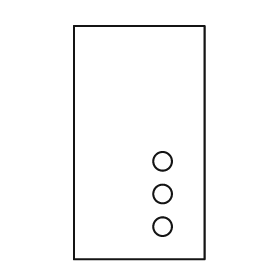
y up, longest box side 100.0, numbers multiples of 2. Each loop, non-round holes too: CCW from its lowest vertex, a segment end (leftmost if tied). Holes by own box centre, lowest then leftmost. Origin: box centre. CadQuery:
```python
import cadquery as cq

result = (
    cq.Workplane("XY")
    .moveTo(-28.0, -50.0)
    .lineTo(28.0, -50.0)
    .lineTo(28.0, 50.0)
    .lineTo(-28.0, 50.0)
    .close()
    .moveTo(10.0, -36.0)
    .circle(4.0)
    .moveTo(10.0, -22.0)
    .circle(4.0)
    .moveTo(10.0, -8.0)
    .circle(4.0)
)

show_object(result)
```